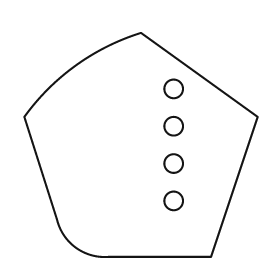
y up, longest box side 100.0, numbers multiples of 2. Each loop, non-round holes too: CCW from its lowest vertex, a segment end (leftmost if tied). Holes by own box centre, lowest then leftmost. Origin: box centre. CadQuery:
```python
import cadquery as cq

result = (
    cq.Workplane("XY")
    .moveTo(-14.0, -48.0)
    .lineTo(30.0, -48.0)
    .lineTo(50.0, 12.0)
    .lineTo(0.0, 48.0)
    .threePointArc((-28.0, 34.0), (-50.0, 12.0))
    .lineTo(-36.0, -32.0)
    .threePointArc((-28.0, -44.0), (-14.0, -48.0))
    .close()
    .moveTo(14.0, -24.0)
    .circle(4.0)
    .moveTo(14.0, -8.0)
    .circle(4.0)
    .moveTo(14.0, 8.0)
    .circle(4.0)
    .moveTo(14.0, 24.0)
    .circle(4.0)
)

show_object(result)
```